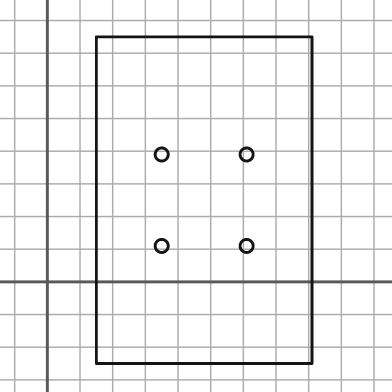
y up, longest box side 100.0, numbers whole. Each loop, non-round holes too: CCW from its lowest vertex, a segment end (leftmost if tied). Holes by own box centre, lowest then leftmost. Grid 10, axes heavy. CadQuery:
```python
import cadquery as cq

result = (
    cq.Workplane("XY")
    .moveTo(15.0, -25.0)
    .lineTo(81.0, -25.0)
    .lineTo(81.0, 75.0)
    .lineTo(15.0, 75.0)
    .close()
    .moveTo(35.0, 11.0)
    .circle(2.0)
    .moveTo(61.0, 11.0)
    .circle(2.0)
    .moveTo(35.0, 39.0)
    .circle(2.0)
    .moveTo(61.0, 39.0)
    .circle(2.0)
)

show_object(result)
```